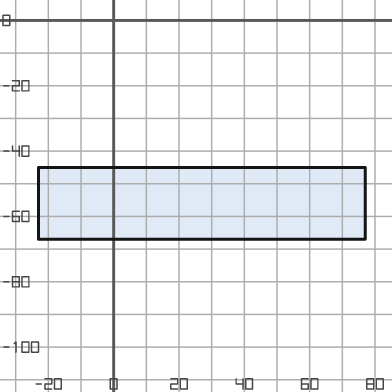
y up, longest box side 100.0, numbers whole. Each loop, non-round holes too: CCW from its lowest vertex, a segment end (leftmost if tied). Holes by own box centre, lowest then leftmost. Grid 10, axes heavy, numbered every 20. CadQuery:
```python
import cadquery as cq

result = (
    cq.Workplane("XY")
    .moveTo(-23.0, -67.0)
    .lineTo(77.0, -67.0)
    .lineTo(77.0, -45.0)
    .lineTo(-23.0, -45.0)
    .close()
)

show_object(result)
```